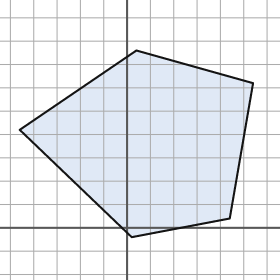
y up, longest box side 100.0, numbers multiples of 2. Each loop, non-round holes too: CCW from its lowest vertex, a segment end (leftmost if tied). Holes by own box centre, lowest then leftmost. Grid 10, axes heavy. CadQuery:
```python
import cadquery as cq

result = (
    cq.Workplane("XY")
    .moveTo(2.0, -4.0)
    .lineTo(44.0, 4.0)
    .lineTo(54.0, 62.0)
    .lineTo(4.0, 76.0)
    .lineTo(-46.0, 42.0)
    .close()
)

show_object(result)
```